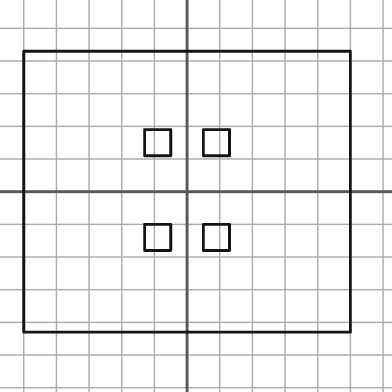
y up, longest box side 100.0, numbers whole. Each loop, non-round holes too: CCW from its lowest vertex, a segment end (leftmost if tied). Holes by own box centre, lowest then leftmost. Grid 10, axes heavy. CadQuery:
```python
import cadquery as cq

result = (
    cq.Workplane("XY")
    .moveTo(-50.0, -43.0)
    .lineTo(50.0, -43.0)
    .lineTo(50.0, 43.0)
    .lineTo(-50.0, 43.0)
    .close()
    .moveTo(-13.0, -18.0)
    .lineTo(-5.0, -18.0)
    .lineTo(-5.0, -10.0)
    .lineTo(-13.0, -10.0)
    .close()
    .moveTo(5.0, -18.0)
    .lineTo(13.0, -18.0)
    .lineTo(13.0, -10.0)
    .lineTo(5.0, -10.0)
    .close()
    .moveTo(-13.0, 11.0)
    .lineTo(-5.0, 11.0)
    .lineTo(-5.0, 19.0)
    .lineTo(-13.0, 19.0)
    .close()
    .moveTo(5.0, 11.0)
    .lineTo(13.0, 11.0)
    .lineTo(13.0, 19.0)
    .lineTo(5.0, 19.0)
    .close()
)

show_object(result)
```